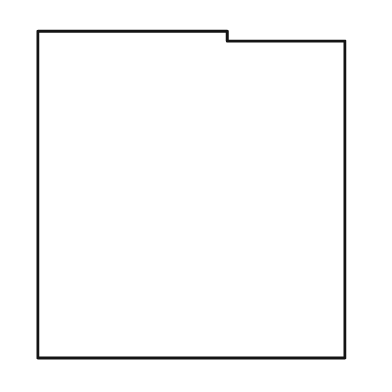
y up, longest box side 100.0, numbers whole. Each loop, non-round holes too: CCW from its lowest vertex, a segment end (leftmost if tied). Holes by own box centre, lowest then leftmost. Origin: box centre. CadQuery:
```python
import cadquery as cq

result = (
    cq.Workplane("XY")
    .moveTo(-47.0, -50.0)
    .lineTo(47.0, -50.0)
    .lineTo(47.0, 47.0)
    .lineTo(11.0, 47.0)
    .lineTo(11.0, 50.0)
    .lineTo(-47.0, 50.0)
    .close()
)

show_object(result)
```